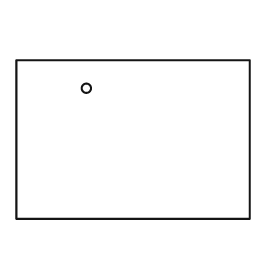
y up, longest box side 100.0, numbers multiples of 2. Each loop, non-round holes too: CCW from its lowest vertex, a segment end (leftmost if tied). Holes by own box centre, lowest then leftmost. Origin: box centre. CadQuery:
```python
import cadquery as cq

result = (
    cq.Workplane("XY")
    .moveTo(-50.0, -34.0)
    .lineTo(50.0, -34.0)
    .lineTo(50.0, 34.0)
    .lineTo(-50.0, 34.0)
    .close()
    .moveTo(-20.0, 22.0)
    .circle(2.0)
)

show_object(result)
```